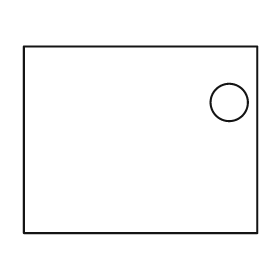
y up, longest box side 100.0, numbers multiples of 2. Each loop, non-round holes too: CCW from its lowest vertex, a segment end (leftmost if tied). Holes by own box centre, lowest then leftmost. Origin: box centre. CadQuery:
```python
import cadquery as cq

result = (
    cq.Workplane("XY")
    .moveTo(-50.0, -40.0)
    .lineTo(50.0, -40.0)
    .lineTo(50.0, 40.0)
    .lineTo(-50.0, 40.0)
    .close()
    .moveTo(38.0, 16.0)
    .circle(8.0)
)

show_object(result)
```